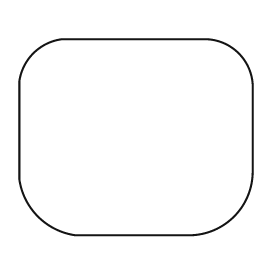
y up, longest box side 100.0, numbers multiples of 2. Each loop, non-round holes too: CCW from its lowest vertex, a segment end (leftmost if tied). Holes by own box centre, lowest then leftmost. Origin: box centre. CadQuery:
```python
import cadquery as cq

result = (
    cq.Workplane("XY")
    .moveTo(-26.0, -42.0)
    .lineTo(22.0, -42.0)
    .threePointArc((42.0, -34.0), (50.0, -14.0))
    .lineTo(50.0, 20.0)
    .threePointArc((44.0, 36.0), (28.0, 42.0))
    .lineTo(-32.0, 42.0)
    .threePointArc((-44.0, 36.0), (-50.0, 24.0))
    .lineTo(-50.0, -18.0)
    .threePointArc((-42.0, -34.0), (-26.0, -42.0))
    .close()
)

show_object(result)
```